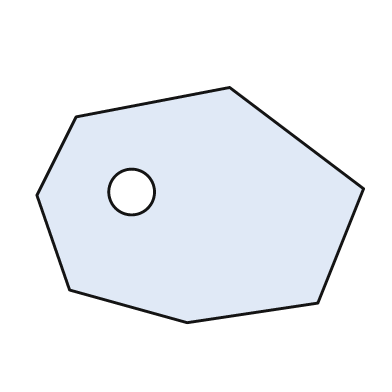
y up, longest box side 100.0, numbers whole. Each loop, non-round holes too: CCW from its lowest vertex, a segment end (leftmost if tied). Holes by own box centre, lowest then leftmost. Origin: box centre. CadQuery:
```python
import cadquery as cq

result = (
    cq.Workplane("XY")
    .moveTo(-4.0, -36.0)
    .lineTo(36.0, -30.0)
    .lineTo(50.0, 5.0)
    .lineTo(9.0, 36.0)
    .lineTo(-38.0, 27.0)
    .lineTo(-50.0, 3.0)
    .lineTo(-40.0, -26.0)
    .close()
    .moveTo(-21.0, 4.0)
    .circle(7.0)
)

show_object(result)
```